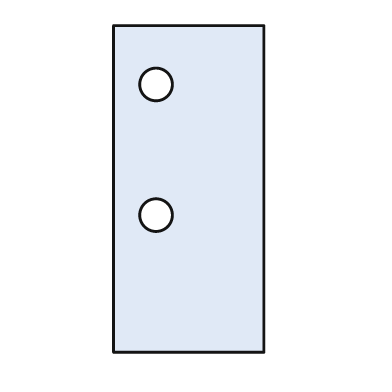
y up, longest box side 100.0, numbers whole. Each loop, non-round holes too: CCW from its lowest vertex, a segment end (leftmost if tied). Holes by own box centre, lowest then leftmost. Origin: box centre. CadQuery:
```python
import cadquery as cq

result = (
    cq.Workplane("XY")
    .moveTo(-23.0, -50.0)
    .lineTo(23.0, -50.0)
    .lineTo(23.0, 50.0)
    .lineTo(-23.0, 50.0)
    .close()
    .moveTo(-10.0, -8.0)
    .circle(5.0)
    .moveTo(-10.0, 32.0)
    .circle(5.0)
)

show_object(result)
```